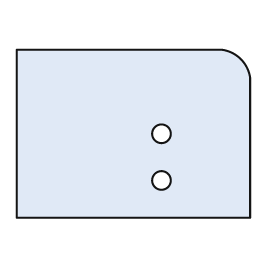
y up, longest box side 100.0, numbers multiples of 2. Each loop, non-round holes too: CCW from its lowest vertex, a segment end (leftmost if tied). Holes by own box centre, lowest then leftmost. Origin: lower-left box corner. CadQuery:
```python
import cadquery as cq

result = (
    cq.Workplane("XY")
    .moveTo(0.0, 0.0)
    .lineTo(100.0, 0.0)
    .lineTo(100.0, 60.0)
    .threePointArc((96.0, 68.0), (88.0, 72.0))
    .lineTo(0.0, 72.0)
    .close()
    .moveTo(62.0, 16.0)
    .circle(4.0)
    .moveTo(62.0, 36.0)
    .circle(4.0)
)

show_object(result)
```